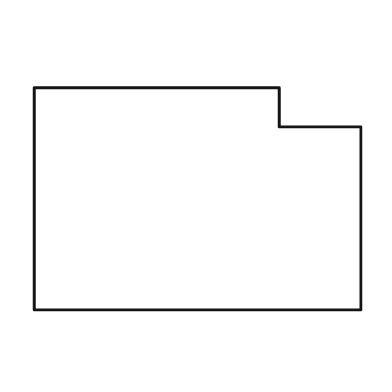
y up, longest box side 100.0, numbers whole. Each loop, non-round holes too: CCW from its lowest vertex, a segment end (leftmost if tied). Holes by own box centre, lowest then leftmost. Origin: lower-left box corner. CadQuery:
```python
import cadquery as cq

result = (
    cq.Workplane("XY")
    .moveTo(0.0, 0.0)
    .lineTo(100.0, 0.0)
    .lineTo(100.0, 56.0)
    .lineTo(75.0, 56.0)
    .lineTo(75.0, 68.0)
    .lineTo(0.0, 68.0)
    .close()
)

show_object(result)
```